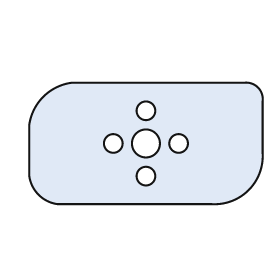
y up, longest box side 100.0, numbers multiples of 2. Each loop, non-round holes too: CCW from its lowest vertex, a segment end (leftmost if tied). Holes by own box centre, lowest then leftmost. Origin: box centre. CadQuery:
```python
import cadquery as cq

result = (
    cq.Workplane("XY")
    .moveTo(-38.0, -26.0)
    .lineTo(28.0, -26.0)
    .threePointArc((44.0, -20.0), (50.0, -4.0))
    .lineTo(50.0, 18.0)
    .threePointArc((48.0, 24.0), (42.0, 26.0))
    .lineTo(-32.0, 26.0)
    .threePointArc((-44.0, 20.0), (-50.0, 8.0))
    .lineTo(-50.0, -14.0)
    .threePointArc((-46.0, -22.0), (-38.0, -26.0))
    .close()
    .moveTo(0.0, -14.0)
    .circle(4.0)
    .moveTo(-14.0, 0.0)
    .circle(4.0)
    .moveTo(0.0, 0.0)
    .circle(6.0)
    .moveTo(14.0, 0.0)
    .circle(4.0)
    .moveTo(0.0, 14.0)
    .circle(4.0)
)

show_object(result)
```